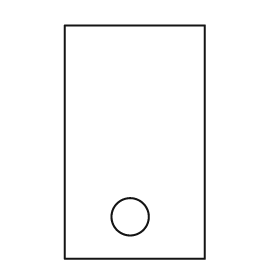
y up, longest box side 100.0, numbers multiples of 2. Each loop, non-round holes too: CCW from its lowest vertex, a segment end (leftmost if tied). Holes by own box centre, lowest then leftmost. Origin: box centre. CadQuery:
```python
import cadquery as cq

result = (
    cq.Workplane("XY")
    .moveTo(-30.0, -50.0)
    .lineTo(30.0, -50.0)
    .lineTo(30.0, 50.0)
    .lineTo(-30.0, 50.0)
    .close()
    .moveTo(-2.0, -32.0)
    .circle(8.0)
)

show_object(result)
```